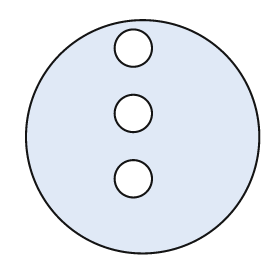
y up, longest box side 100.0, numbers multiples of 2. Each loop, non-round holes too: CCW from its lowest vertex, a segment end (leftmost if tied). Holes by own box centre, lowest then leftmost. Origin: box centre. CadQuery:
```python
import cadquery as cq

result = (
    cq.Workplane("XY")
    .moveTo(0.0, 0.0)
    .circle(50.0)
    .moveTo(-4.0, -18.0)
    .circle(8.0)
    .moveTo(-4.0, 10.0)
    .circle(8.0)
    .moveTo(-4.0, 38.0)
    .circle(8.0)
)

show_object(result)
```